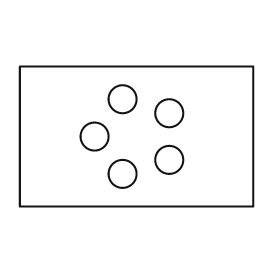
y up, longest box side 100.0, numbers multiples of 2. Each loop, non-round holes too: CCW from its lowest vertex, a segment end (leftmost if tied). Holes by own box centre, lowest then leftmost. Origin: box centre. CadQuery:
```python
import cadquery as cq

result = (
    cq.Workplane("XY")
    .moveTo(-50.0, -30.0)
    .lineTo(50.0, -30.0)
    .lineTo(50.0, 30.0)
    .lineTo(-50.0, 30.0)
    .close()
    .moveTo(-6.0, -16.0)
    .circle(6.0)
    .moveTo(14.0, -10.0)
    .circle(6.0)
    .moveTo(-18.0, 0.0)
    .circle(6.0)
    .moveTo(14.0, 10.0)
    .circle(6.0)
    .moveTo(-6.0, 16.0)
    .circle(6.0)
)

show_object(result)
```